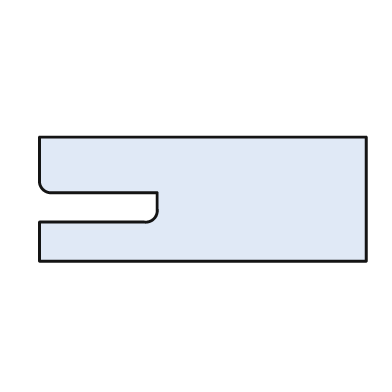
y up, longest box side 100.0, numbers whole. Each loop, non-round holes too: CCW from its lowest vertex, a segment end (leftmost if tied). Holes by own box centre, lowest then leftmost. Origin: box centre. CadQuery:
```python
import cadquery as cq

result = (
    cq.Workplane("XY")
    .moveTo(-50.0, -19.0)
    .lineTo(50.0, -19.0)
    .lineTo(50.0, 19.0)
    .lineTo(-50.0, 19.0)
    .lineTo(-50.0, 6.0)
    .threePointArc((-49.0, 3.0), (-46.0, 2.0))
    .lineTo(-14.0, 2.0)
    .lineTo(-14.0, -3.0)
    .threePointArc((-15.0, -6.0), (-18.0, -7.0))
    .lineTo(-50.0, -7.0)
    .close()
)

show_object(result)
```